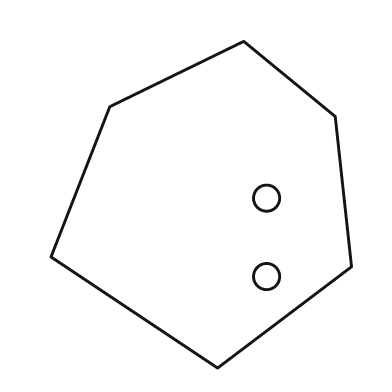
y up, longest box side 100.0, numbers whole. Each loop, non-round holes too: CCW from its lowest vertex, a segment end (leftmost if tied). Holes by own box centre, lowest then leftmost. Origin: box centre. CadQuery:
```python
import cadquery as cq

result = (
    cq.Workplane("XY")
    .moveTo(5.0, -50.0)
    .lineTo(46.0, -19.0)
    .lineTo(41.0, 27.0)
    .lineTo(13.0, 50.0)
    .lineTo(-28.0, 30.0)
    .lineTo(-46.0, -16.0)
    .close()
    .moveTo(20.0, -22.0)
    .circle(4.0)
    .moveTo(20.0, 2.0)
    .circle(4.0)
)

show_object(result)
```